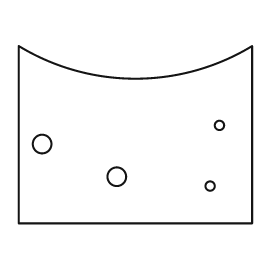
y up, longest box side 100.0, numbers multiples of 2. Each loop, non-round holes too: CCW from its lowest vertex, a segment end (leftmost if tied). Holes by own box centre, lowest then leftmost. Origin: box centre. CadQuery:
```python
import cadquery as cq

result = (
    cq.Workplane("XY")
    .moveTo(-50.0, -38.0)
    .lineTo(50.0, -38.0)
    .lineTo(50.0, 38.0)
    .threePointArc((0.0, 24.0), (-50.0, 38.0))
    .close()
    .moveTo(32.0, -22.0)
    .circle(2.0)
    .moveTo(-8.0, -18.0)
    .circle(4.0)
    .moveTo(-40.0, -4.0)
    .circle(4.0)
    .moveTo(36.0, 4.0)
    .circle(2.0)
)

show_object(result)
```